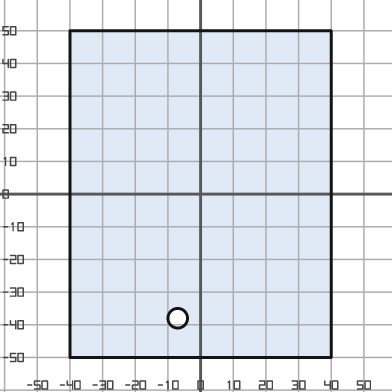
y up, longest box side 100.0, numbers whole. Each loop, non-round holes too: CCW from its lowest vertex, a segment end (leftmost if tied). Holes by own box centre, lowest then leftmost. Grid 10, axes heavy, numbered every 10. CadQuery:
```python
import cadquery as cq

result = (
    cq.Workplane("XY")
    .moveTo(-40.0, -50.0)
    .lineTo(40.0, -50.0)
    .lineTo(40.0, 50.0)
    .lineTo(-40.0, 50.0)
    .close()
    .moveTo(-7.0, -38.0)
    .circle(3.0)
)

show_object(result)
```